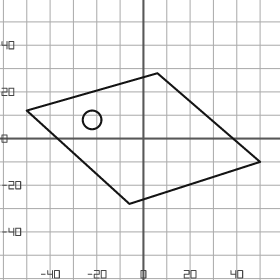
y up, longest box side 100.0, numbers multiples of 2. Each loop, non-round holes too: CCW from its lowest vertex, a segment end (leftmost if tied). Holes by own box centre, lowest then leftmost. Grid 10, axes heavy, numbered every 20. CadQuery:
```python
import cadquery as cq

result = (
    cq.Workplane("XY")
    .moveTo(-6.0, -28.0)
    .lineTo(50.0, -10.0)
    .lineTo(6.0, 28.0)
    .lineTo(-50.0, 12.0)
    .close()
    .moveTo(-22.0, 8.0)
    .circle(4.0)
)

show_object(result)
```